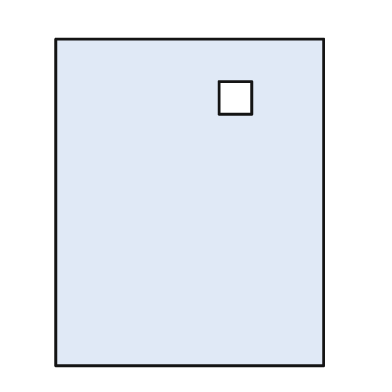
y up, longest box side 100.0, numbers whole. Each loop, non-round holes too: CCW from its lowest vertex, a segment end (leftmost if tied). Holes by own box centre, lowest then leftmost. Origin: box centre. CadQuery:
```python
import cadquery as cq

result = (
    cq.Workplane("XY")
    .moveTo(-41.0, -50.0)
    .lineTo(41.0, -50.0)
    .lineTo(41.0, 50.0)
    .lineTo(-41.0, 50.0)
    .close()
    .moveTo(9.0, 27.0)
    .lineTo(19.0, 27.0)
    .lineTo(19.0, 37.0)
    .lineTo(9.0, 37.0)
    .close()
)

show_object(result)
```